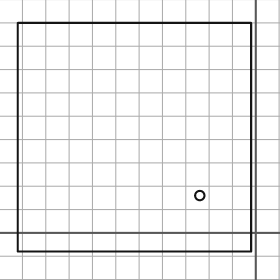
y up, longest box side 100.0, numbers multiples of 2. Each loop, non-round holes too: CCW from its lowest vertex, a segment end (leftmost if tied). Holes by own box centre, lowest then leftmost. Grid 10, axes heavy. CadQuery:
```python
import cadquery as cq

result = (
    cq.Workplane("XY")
    .moveTo(-102.0, -8.0)
    .lineTo(-2.0, -8.0)
    .lineTo(-2.0, 90.0)
    .lineTo(-102.0, 90.0)
    .close()
    .moveTo(-24.0, 16.0)
    .circle(2.0)
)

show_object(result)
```